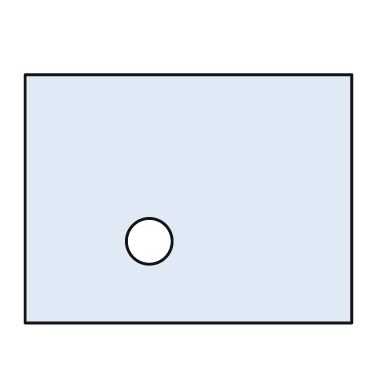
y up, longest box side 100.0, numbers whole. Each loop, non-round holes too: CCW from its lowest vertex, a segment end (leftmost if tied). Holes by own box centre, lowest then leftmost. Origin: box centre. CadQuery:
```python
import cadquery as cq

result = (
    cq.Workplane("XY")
    .moveTo(-50.0, -38.0)
    .lineTo(50.0, -38.0)
    .lineTo(50.0, 38.0)
    .lineTo(-50.0, 38.0)
    .close()
    .moveTo(-12.0, -13.0)
    .circle(7.0)
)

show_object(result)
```